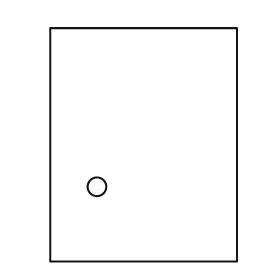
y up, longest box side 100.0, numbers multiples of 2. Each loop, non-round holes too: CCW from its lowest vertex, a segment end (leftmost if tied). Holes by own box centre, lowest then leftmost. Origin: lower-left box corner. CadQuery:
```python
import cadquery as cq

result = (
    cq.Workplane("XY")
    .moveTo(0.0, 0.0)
    .lineTo(80.0, 0.0)
    .lineTo(80.0, 100.0)
    .lineTo(0.0, 100.0)
    .close()
    .moveTo(20.0, 32.0)
    .circle(4.0)
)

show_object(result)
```